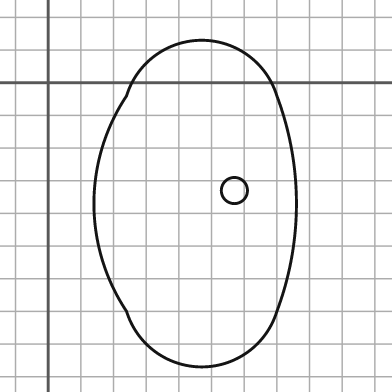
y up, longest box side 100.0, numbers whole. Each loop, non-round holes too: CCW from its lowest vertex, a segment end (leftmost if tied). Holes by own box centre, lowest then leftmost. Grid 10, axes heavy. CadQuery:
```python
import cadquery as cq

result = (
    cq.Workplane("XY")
    .moveTo(24.0, -70.0)
    .threePointArc((47.0, -87.0), (70.0, -70.0))
    .threePointArc((76.0, -37.0), (70.0, -4.0))
    .threePointArc((47.0, 13.0), (24.0, -4.0))
    .threePointArc((14.0, -37.0), (24.0, -70.0))
    .close()
    .moveTo(57.0, -33.0)
    .circle(4.0)
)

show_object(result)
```